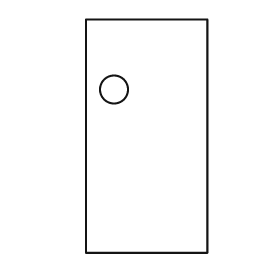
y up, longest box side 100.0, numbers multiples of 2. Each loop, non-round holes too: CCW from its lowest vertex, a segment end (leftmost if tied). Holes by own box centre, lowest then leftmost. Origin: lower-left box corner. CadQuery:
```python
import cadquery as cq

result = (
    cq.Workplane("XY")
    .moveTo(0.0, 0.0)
    .lineTo(52.0, 0.0)
    .lineTo(52.0, 100.0)
    .lineTo(0.0, 100.0)
    .close()
    .moveTo(12.0, 70.0)
    .circle(6.0)
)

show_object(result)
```